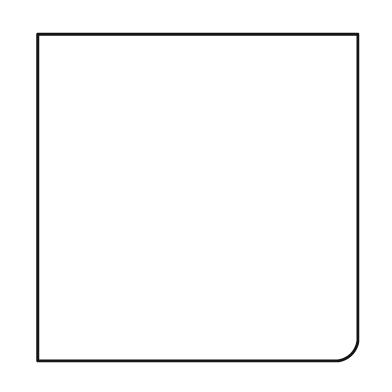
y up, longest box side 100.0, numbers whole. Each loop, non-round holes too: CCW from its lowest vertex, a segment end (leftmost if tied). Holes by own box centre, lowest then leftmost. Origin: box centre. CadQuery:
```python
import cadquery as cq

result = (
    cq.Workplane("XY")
    .moveTo(-49.0, -50.0)
    .lineTo(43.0, -50.0)
    .threePointArc((47.0, -48.0), (49.0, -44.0))
    .lineTo(49.0, 50.0)
    .lineTo(-49.0, 50.0)
    .close()
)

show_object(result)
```